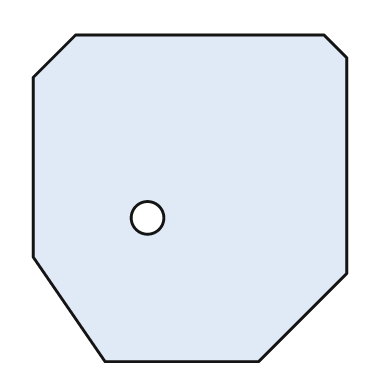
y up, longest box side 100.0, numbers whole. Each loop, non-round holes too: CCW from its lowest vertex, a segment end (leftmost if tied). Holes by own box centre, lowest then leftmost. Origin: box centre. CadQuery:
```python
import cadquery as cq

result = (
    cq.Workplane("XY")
    .moveTo(-26.0, -50.0)
    .lineTo(21.0, -50.0)
    .lineTo(48.0, -23.0)
    .lineTo(48.0, 43.0)
    .lineTo(41.0, 50.0)
    .lineTo(-35.0, 50.0)
    .lineTo(-48.0, 37.0)
    .lineTo(-48.0, -18.0)
    .close()
    .moveTo(-13.0, -6.0)
    .circle(5.0)
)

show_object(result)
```